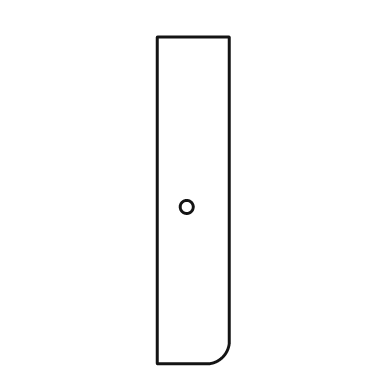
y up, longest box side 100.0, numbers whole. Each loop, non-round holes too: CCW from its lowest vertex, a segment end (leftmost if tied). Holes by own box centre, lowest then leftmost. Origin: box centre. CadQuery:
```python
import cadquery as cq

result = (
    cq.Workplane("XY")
    .moveTo(-11.0, -50.0)
    .lineTo(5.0, -50.0)
    .threePointArc((9.0, -48.0), (11.0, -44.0))
    .lineTo(11.0, 50.0)
    .lineTo(-11.0, 50.0)
    .close()
    .moveTo(-2.0, -2.0)
    .circle(2.0)
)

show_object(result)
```